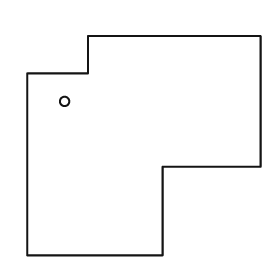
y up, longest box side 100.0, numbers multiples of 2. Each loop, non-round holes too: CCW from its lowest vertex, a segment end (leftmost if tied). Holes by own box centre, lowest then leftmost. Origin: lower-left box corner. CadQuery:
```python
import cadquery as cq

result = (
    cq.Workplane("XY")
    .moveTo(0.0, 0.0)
    .lineTo(58.0, 0.0)
    .lineTo(58.0, 38.0)
    .lineTo(100.0, 38.0)
    .lineTo(100.0, 94.0)
    .lineTo(26.0, 94.0)
    .lineTo(26.0, 78.0)
    .lineTo(0.0, 78.0)
    .close()
    .moveTo(16.0, 66.0)
    .circle(2.0)
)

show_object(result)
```